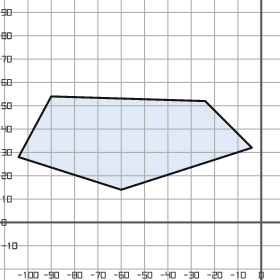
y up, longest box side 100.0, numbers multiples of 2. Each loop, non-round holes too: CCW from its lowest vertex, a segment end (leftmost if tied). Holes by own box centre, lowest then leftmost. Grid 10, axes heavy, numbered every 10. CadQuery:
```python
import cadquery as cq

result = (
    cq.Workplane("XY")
    .moveTo(-60.0, 14.0)
    .lineTo(-4.0, 32.0)
    .lineTo(-24.0, 52.0)
    .lineTo(-90.0, 54.0)
    .lineTo(-104.0, 28.0)
    .close()
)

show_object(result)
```